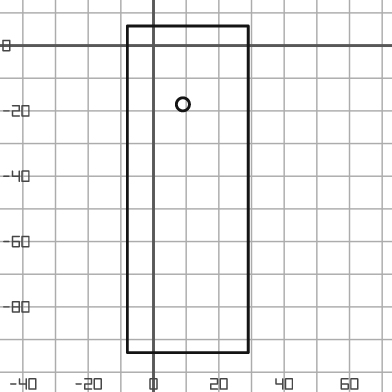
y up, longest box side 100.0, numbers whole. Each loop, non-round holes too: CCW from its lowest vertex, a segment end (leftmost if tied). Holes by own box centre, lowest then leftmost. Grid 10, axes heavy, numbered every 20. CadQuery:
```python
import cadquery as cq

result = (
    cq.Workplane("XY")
    .moveTo(-8.0, -94.0)
    .lineTo(29.0, -94.0)
    .lineTo(29.0, 6.0)
    .lineTo(-8.0, 6.0)
    .close()
    .moveTo(9.0, -18.0)
    .circle(2.0)
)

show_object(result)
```